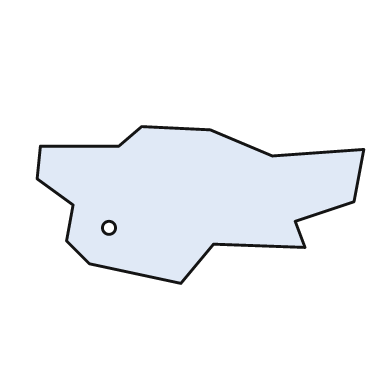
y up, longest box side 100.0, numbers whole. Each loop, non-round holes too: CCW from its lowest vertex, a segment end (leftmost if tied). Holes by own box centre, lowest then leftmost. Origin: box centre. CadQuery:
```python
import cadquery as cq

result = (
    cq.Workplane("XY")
    .moveTo(-6.0, -24.0)
    .lineTo(4.0, -12.0)
    .lineTo(32.0, -13.0)
    .lineTo(29.0, -5.0)
    .lineTo(47.0, 1.0)
    .lineTo(50.0, 17.0)
    .lineTo(22.0, 15.0)
    .lineTo(3.0, 23.0)
    .lineTo(-18.0, 24.0)
    .lineTo(-25.0, 18.0)
    .lineTo(-49.0, 18.0)
    .lineTo(-50.0, 8.0)
    .lineTo(-39.0, 0.0)
    .lineTo(-41.0, -11.0)
    .lineTo(-34.0, -18.0)
    .close()
    .moveTo(-28.0, -7.0)
    .circle(2.0)
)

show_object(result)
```